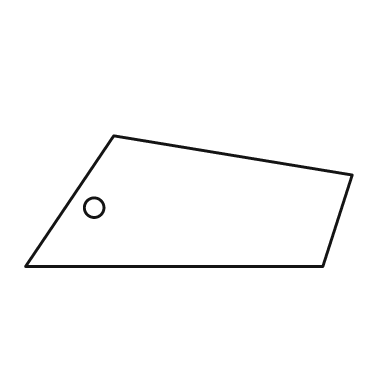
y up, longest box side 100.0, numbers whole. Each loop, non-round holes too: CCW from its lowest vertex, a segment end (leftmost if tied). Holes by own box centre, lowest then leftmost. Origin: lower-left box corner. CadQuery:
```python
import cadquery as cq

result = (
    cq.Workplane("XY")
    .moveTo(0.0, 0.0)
    .lineTo(91.0, 0.0)
    .lineTo(100.0, 28.0)
    .lineTo(27.0, 40.0)
    .close()
    .moveTo(21.0, 18.0)
    .circle(3.0)
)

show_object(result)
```